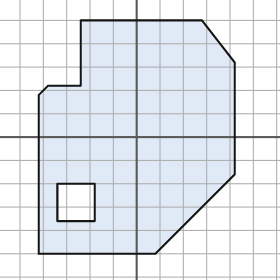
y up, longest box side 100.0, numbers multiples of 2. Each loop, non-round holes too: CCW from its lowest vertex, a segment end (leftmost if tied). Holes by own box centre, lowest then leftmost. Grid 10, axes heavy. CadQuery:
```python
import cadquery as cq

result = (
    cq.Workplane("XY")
    .moveTo(-42.0, -50.0)
    .lineTo(8.0, -50.0)
    .lineTo(42.0, -16.0)
    .lineTo(42.0, 32.0)
    .lineTo(28.0, 50.0)
    .lineTo(-24.0, 50.0)
    .lineTo(-24.0, 22.0)
    .lineTo(-38.0, 22.0)
    .lineTo(-42.0, 18.0)
    .close()
    .moveTo(-34.0, -36.0)
    .lineTo(-18.0, -36.0)
    .lineTo(-18.0, -20.0)
    .lineTo(-34.0, -20.0)
    .close()
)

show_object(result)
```